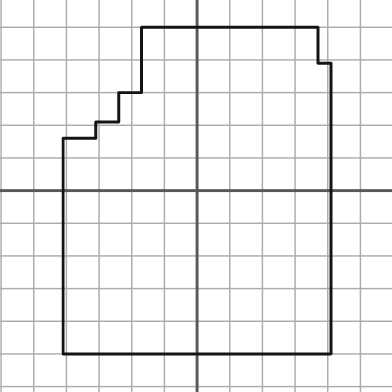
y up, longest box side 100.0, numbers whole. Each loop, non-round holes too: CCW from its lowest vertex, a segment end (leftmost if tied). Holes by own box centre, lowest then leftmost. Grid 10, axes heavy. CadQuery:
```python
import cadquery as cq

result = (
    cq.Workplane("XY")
    .moveTo(-41.0, -50.0)
    .lineTo(41.0, -50.0)
    .lineTo(41.0, 39.0)
    .lineTo(37.0, 39.0)
    .lineTo(37.0, 50.0)
    .lineTo(-17.0, 50.0)
    .lineTo(-17.0, 30.0)
    .lineTo(-24.0, 30.0)
    .lineTo(-24.0, 21.0)
    .lineTo(-31.0, 21.0)
    .lineTo(-31.0, 16.0)
    .lineTo(-41.0, 16.0)
    .close()
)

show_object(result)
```